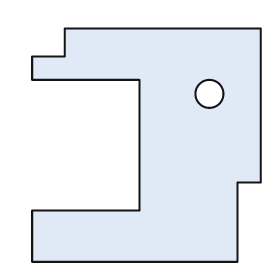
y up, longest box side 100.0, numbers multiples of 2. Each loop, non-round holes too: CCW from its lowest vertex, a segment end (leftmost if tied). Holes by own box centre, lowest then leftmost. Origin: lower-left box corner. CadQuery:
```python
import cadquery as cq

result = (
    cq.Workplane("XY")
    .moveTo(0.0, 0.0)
    .lineTo(88.0, 0.0)
    .lineTo(88.0, 34.0)
    .lineTo(98.0, 34.0)
    .lineTo(98.0, 100.0)
    .lineTo(14.0, 100.0)
    .lineTo(14.0, 88.0)
    .lineTo(0.0, 88.0)
    .lineTo(0.0, 78.0)
    .lineTo(46.0, 78.0)
    .lineTo(46.0, 22.0)
    .lineTo(0.0, 22.0)
    .close()
    .moveTo(76.0, 72.0)
    .circle(6.0)
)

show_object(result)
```